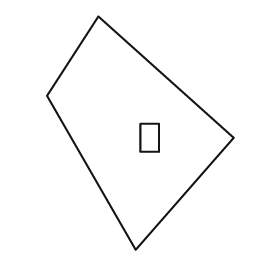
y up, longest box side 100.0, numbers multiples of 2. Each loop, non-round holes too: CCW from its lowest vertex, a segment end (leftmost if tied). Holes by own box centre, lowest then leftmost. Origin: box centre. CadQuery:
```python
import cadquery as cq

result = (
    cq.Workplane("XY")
    .moveTo(-2.0, -50.0)
    .lineTo(40.0, -2.0)
    .lineTo(-18.0, 50.0)
    .lineTo(-40.0, 16.0)
    .close()
    .moveTo(0.0, -8.0)
    .lineTo(8.0, -8.0)
    .lineTo(8.0, 4.0)
    .lineTo(0.0, 4.0)
    .close()
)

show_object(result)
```